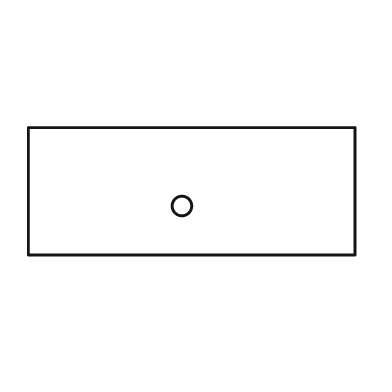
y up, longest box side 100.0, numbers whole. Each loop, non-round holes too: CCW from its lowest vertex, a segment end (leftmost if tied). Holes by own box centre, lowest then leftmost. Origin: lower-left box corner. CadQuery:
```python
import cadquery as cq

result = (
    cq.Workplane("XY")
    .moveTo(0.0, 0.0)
    .lineTo(100.0, 0.0)
    .lineTo(100.0, 39.0)
    .lineTo(0.0, 39.0)
    .close()
    .moveTo(47.0, 15.0)
    .circle(3.0)
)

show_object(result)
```